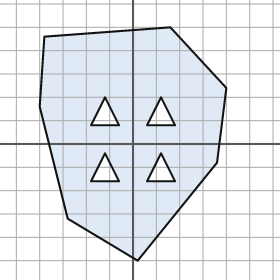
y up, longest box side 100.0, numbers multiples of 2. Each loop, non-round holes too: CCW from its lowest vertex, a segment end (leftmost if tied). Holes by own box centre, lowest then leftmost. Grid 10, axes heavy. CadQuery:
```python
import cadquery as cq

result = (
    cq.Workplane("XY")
    .moveTo(2.0, -50.0)
    .lineTo(36.0, -8.0)
    .lineTo(40.0, 24.0)
    .lineTo(16.0, 50.0)
    .lineTo(-38.0, 46.0)
    .lineTo(-40.0, 16.0)
    .lineTo(-28.0, -32.0)
    .close()
    .moveTo(-18.0, -16.0)
    .lineTo(-6.0, -16.0)
    .lineTo(-12.0, -4.0)
    .close()
    .moveTo(6.0, -16.0)
    .lineTo(18.0, -16.0)
    .lineTo(12.0, -4.0)
    .close()
    .moveTo(-18.0, 8.0)
    .lineTo(-6.0, 8.0)
    .lineTo(-12.0, 20.0)
    .close()
    .moveTo(6.0, 8.0)
    .lineTo(18.0, 8.0)
    .lineTo(12.0, 20.0)
    .close()
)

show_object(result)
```